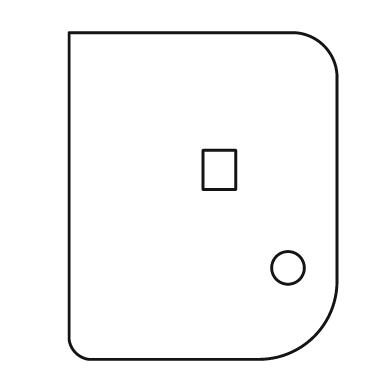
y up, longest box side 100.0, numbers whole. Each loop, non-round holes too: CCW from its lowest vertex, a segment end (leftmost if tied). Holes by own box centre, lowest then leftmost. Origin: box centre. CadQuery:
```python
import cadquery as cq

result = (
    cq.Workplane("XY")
    .moveTo(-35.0, -50.0)
    .lineTo(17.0, -50.0)
    .threePointArc((34.0, -43.0), (41.0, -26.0))
    .lineTo(41.0, 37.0)
    .threePointArc((37.0, 46.0), (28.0, 50.0))
    .lineTo(-41.0, 50.0)
    .lineTo(-41.0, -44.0)
    .threePointArc((-39.0, -48.0), (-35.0, -50.0))
    .close()
    .moveTo(26.0, -22.0)
    .circle(5.0)
    .moveTo(0.0, 2.0)
    .lineTo(10.0, 2.0)
    .lineTo(10.0, 14.0)
    .lineTo(0.0, 14.0)
    .close()
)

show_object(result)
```